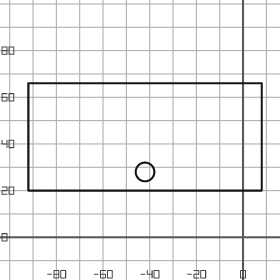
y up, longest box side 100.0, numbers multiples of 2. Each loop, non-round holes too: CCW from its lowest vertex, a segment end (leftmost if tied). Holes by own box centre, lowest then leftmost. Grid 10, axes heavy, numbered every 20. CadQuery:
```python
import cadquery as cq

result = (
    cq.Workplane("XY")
    .moveTo(-92.0, 20.0)
    .lineTo(8.0, 20.0)
    .lineTo(8.0, 66.0)
    .lineTo(-92.0, 66.0)
    .close()
    .moveTo(-42.0, 28.0)
    .circle(4.0)
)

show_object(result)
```